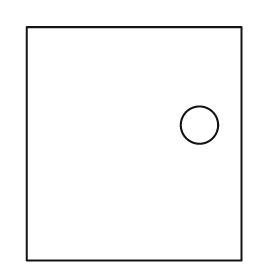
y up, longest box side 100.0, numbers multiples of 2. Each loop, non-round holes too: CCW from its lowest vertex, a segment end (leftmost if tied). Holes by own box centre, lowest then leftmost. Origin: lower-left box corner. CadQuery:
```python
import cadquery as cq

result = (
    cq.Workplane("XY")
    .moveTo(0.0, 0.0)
    .lineTo(92.0, 0.0)
    .lineTo(92.0, 100.0)
    .lineTo(0.0, 100.0)
    .close()
    .moveTo(74.0, 58.0)
    .circle(8.0)
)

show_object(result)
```